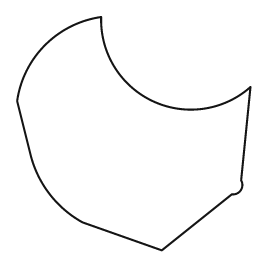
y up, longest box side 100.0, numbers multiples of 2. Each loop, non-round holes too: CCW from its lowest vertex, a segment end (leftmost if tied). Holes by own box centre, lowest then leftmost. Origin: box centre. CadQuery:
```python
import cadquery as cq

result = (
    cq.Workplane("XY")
    .moveTo(12.0, -50.0)
    .lineTo(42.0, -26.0)
    .threePointArc((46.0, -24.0), (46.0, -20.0))
    .lineTo(50.0, 20.0)
    .threePointArc((8.0, 14.0), (-14.0, 50.0))
    .threePointArc((-38.0, 38.0), (-50.0, 14.0))
    .lineTo(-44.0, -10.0)
    .threePointArc((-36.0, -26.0), (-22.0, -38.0))
    .close()
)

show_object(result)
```